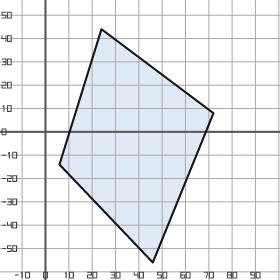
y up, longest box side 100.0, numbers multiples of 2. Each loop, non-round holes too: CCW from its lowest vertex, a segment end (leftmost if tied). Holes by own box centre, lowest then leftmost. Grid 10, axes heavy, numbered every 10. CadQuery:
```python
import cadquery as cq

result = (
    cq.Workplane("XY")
    .moveTo(46.0, -56.0)
    .lineTo(72.0, 8.0)
    .lineTo(24.0, 44.0)
    .lineTo(6.0, -14.0)
    .close()
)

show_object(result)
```